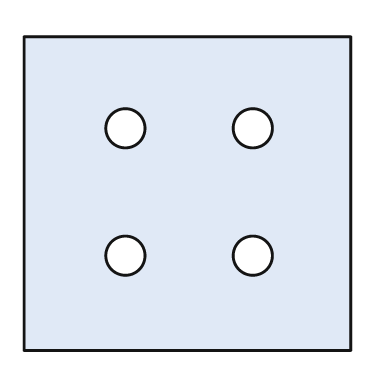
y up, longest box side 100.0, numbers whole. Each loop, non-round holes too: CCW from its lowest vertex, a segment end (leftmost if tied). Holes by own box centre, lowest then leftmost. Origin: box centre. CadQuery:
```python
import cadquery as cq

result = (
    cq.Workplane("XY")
    .moveTo(-50.0, -48.0)
    .lineTo(50.0, -48.0)
    .lineTo(50.0, 48.0)
    .lineTo(-50.0, 48.0)
    .close()
    .moveTo(-19.0, -19.0)
    .circle(6.0)
    .moveTo(20.0, -19.0)
    .circle(6.0)
    .moveTo(-19.0, 20.0)
    .circle(6.0)
    .moveTo(20.0, 20.0)
    .circle(6.0)
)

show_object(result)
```